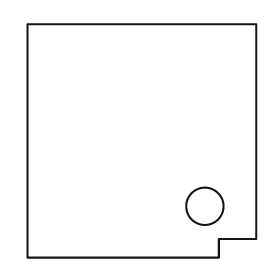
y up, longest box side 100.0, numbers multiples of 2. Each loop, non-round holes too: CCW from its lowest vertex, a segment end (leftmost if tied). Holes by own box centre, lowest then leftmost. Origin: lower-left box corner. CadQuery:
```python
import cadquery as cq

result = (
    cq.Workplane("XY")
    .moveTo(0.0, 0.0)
    .lineTo(82.0, 0.0)
    .lineTo(82.0, 8.0)
    .lineTo(98.0, 8.0)
    .lineTo(98.0, 100.0)
    .lineTo(0.0, 100.0)
    .close()
    .moveTo(76.0, 22.0)
    .circle(8.0)
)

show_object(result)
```